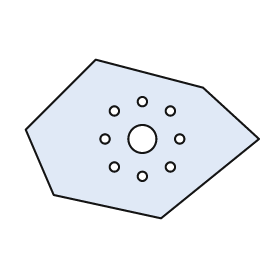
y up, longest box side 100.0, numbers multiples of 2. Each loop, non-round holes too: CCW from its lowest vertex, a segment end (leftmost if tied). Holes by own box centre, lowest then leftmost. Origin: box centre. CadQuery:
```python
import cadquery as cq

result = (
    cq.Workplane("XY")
    .moveTo(8.0, -34.0)
    .lineTo(50.0, 0.0)
    .lineTo(26.0, 22.0)
    .lineTo(-20.0, 34.0)
    .lineTo(-50.0, 4.0)
    .lineTo(-38.0, -24.0)
    .close()
    .moveTo(0.0, -16.0)
    .circle(2.0)
    .moveTo(-12.0, -12.0)
    .circle(2.0)
    .moveTo(12.0, -12.0)
    .circle(2.0)
    .moveTo(-16.0, 0.0)
    .circle(2.0)
    .moveTo(0.0, 0.0)
    .circle(6.0)
    .moveTo(16.0, 0.0)
    .circle(2.0)
    .moveTo(-12.0, 12.0)
    .circle(2.0)
    .moveTo(12.0, 12.0)
    .circle(2.0)
    .moveTo(0.0, 16.0)
    .circle(2.0)
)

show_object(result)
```